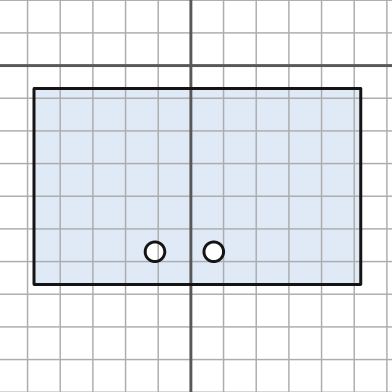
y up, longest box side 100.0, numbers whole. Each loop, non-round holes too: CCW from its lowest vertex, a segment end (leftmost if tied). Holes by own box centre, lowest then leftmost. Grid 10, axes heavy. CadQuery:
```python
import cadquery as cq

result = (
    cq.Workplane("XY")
    .moveTo(-48.0, -67.0)
    .lineTo(52.0, -67.0)
    .lineTo(52.0, -7.0)
    .lineTo(-48.0, -7.0)
    .close()
    .moveTo(-11.0, -57.0)
    .circle(3.0)
    .moveTo(7.0, -57.0)
    .circle(3.0)
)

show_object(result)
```